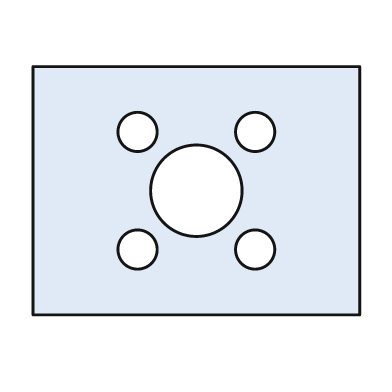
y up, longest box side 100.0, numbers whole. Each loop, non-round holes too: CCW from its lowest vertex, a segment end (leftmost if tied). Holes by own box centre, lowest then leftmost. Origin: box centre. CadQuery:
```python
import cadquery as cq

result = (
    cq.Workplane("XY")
    .moveTo(-50.0, -38.0)
    .lineTo(50.0, -38.0)
    .lineTo(50.0, 38.0)
    .lineTo(-50.0, 38.0)
    .close()
    .moveTo(-18.0, -18.0)
    .circle(6.0)
    .moveTo(18.0, -18.0)
    .circle(6.0)
    .moveTo(0.0, 0.0)
    .circle(14.0)
    .moveTo(-18.0, 18.0)
    .circle(6.0)
    .moveTo(18.0, 18.0)
    .circle(6.0)
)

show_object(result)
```